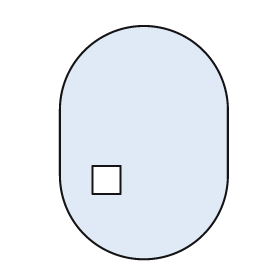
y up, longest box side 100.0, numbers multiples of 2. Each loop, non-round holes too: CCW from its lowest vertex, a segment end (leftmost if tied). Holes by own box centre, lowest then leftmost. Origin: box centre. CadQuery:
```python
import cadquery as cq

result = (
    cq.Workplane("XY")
    .moveTo(-36.0, -14.0)
    .threePointArc((0.0, -50.0), (36.0, -14.0))
    .lineTo(36.0, 14.0)
    .threePointArc((0.0, 50.0), (-36.0, 14.0))
    .close()
    .moveTo(-22.0, -22.0)
    .lineTo(-10.0, -22.0)
    .lineTo(-10.0, -10.0)
    .lineTo(-22.0, -10.0)
    .close()
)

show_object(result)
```